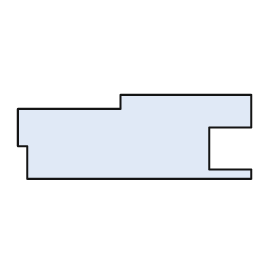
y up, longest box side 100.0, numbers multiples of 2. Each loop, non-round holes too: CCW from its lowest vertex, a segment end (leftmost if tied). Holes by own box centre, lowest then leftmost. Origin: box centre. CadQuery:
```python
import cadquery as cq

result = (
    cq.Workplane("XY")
    .moveTo(-46.0, -18.0)
    .lineTo(50.0, -18.0)
    .lineTo(50.0, -14.0)
    .lineTo(32.0, -14.0)
    .lineTo(32.0, 4.0)
    .lineTo(50.0, 4.0)
    .lineTo(50.0, 18.0)
    .lineTo(-6.0, 18.0)
    .lineTo(-6.0, 12.0)
    .lineTo(-50.0, 12.0)
    .lineTo(-50.0, -4.0)
    .lineTo(-46.0, -4.0)
    .close()
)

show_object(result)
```